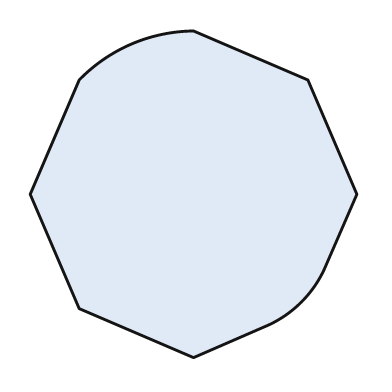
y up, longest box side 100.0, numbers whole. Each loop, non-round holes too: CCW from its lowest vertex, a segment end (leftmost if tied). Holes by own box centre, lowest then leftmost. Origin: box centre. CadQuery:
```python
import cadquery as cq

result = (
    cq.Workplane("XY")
    .moveTo(0.0, -50.0)
    .lineTo(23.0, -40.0)
    .threePointArc((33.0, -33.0), (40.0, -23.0))
    .lineTo(50.0, 0.0)
    .lineTo(35.0, 35.0)
    .lineTo(0.0, 50.0)
    .threePointArc((-19.0, 46.0), (-35.0, 35.0))
    .lineTo(-50.0, 0.0)
    .lineTo(-35.0, -35.0)
    .close()
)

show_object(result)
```